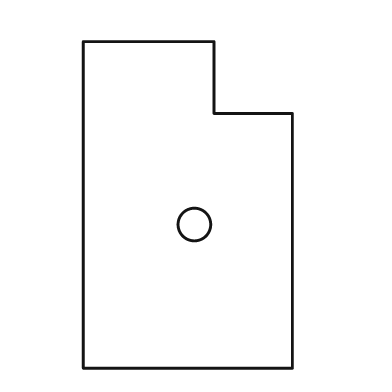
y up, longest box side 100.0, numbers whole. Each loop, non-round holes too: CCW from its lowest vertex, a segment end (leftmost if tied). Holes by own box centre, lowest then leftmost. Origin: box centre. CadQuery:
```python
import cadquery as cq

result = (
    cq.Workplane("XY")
    .moveTo(-32.0, -50.0)
    .lineTo(32.0, -50.0)
    .lineTo(32.0, 28.0)
    .lineTo(8.0, 28.0)
    .lineTo(8.0, 50.0)
    .lineTo(-32.0, 50.0)
    .close()
    .moveTo(2.0, -6.0)
    .circle(5.0)
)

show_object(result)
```